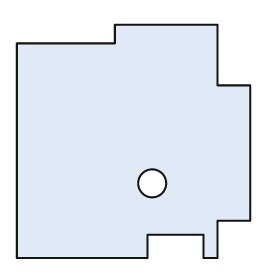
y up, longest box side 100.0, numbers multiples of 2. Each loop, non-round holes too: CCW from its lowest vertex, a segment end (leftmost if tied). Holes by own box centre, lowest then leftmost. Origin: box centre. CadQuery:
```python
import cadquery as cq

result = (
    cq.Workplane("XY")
    .moveTo(-50.0, -50.0)
    .lineTo(6.0, -50.0)
    .lineTo(6.0, -40.0)
    .lineTo(30.0, -40.0)
    .lineTo(30.0, -50.0)
    .lineTo(36.0, -50.0)
    .lineTo(36.0, -34.0)
    .lineTo(50.0, -34.0)
    .lineTo(50.0, 24.0)
    .lineTo(36.0, 24.0)
    .lineTo(36.0, 50.0)
    .lineTo(-8.0, 50.0)
    .lineTo(-8.0, 42.0)
    .lineTo(-50.0, 42.0)
    .close()
    .moveTo(8.0, -18.0)
    .circle(6.0)
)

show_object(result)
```